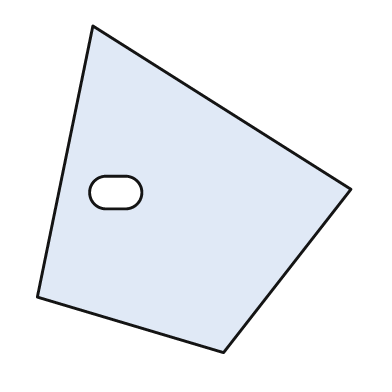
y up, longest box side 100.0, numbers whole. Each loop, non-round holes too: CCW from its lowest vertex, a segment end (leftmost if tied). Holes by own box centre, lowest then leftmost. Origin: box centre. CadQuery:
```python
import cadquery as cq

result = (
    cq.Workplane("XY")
    .moveTo(9.0, -50.0)
    .lineTo(48.0, 0.0)
    .lineTo(-31.0, 50.0)
    .lineTo(-48.0, -33.0)
    .close()
    .moveTo(-27.0, -6.0)
    .lineTo(-21.0, -6.0)
    .threePointArc((-16.0, -1.0), (-21.0, 4.0))
    .lineTo(-27.0, 4.0)
    .threePointArc((-32.0, -1.0), (-27.0, -6.0))
    .close()
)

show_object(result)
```